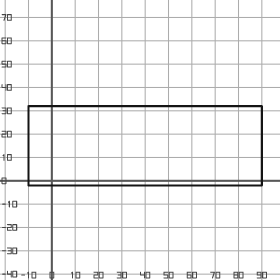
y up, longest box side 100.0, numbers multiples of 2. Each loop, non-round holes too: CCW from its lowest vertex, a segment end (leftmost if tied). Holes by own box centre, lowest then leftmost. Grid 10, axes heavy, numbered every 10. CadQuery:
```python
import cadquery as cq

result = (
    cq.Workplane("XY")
    .moveTo(-10.0, -2.0)
    .lineTo(90.0, -2.0)
    .lineTo(90.0, 32.0)
    .lineTo(-10.0, 32.0)
    .close()
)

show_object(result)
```